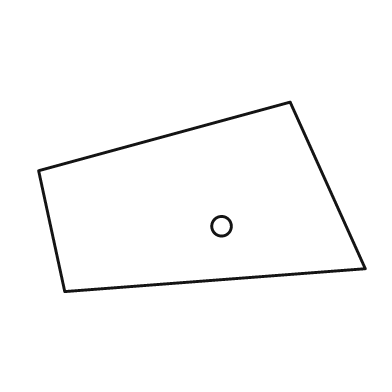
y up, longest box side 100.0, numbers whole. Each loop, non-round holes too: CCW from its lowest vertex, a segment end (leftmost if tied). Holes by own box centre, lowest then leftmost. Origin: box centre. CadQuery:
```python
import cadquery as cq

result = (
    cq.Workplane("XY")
    .moveTo(-42.0, -29.0)
    .lineTo(50.0, -22.0)
    .lineTo(27.0, 29.0)
    .lineTo(-50.0, 8.0)
    .close()
    .moveTo(6.0, -9.0)
    .circle(3.0)
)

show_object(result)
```